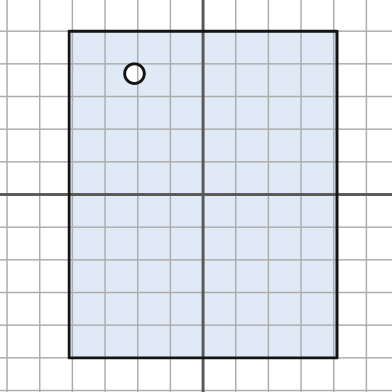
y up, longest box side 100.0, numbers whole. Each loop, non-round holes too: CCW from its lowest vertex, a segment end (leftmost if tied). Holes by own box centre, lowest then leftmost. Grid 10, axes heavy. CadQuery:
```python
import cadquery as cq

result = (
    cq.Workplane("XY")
    .moveTo(-41.0, -50.0)
    .lineTo(41.0, -50.0)
    .lineTo(41.0, 50.0)
    .lineTo(-41.0, 50.0)
    .close()
    .moveTo(-21.0, 37.0)
    .circle(3.0)
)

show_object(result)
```